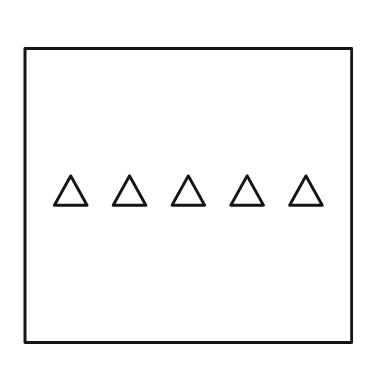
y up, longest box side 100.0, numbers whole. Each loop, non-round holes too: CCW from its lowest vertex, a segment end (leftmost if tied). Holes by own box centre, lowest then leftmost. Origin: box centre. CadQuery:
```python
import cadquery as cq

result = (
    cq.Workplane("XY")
    .moveTo(-50.0, -45.0)
    .lineTo(50.0, -45.0)
    .lineTo(50.0, 45.0)
    .lineTo(-50.0, 45.0)
    .close()
    .moveTo(-41.0, -3.0)
    .lineTo(-31.0, -3.0)
    .lineTo(-36.0, 6.0)
    .close()
    .moveTo(-23.0, -3.0)
    .lineTo(-13.0, -3.0)
    .lineTo(-18.0, 6.0)
    .close()
    .moveTo(-5.0, -3.0)
    .lineTo(5.0, -3.0)
    .lineTo(0.0, 6.0)
    .close()
    .moveTo(13.0, -3.0)
    .lineTo(23.0, -3.0)
    .lineTo(18.0, 6.0)
    .close()
    .moveTo(31.0, -3.0)
    .lineTo(41.0, -3.0)
    .lineTo(36.0, 6.0)
    .close()
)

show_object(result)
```